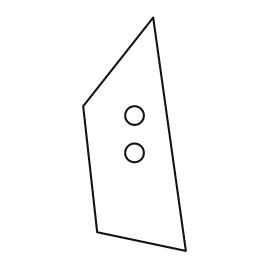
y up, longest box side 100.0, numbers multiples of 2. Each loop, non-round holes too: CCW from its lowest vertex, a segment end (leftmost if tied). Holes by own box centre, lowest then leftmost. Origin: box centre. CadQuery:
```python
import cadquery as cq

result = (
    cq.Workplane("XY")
    .moveTo(22.0, -50.0)
    .lineTo(8.0, 50.0)
    .lineTo(-22.0, 12.0)
    .lineTo(-16.0, -42.0)
    .close()
    .moveTo(0.0, -8.0)
    .circle(4.0)
    .moveTo(0.0, 8.0)
    .circle(4.0)
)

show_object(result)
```